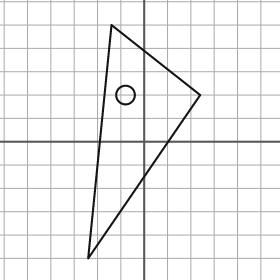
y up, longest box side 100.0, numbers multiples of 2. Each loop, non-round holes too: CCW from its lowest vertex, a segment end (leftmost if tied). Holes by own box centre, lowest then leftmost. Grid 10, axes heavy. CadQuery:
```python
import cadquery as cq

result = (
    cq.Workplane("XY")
    .moveTo(-24.0, -50.0)
    .lineTo(24.0, 20.0)
    .lineTo(-14.0, 50.0)
    .close()
    .moveTo(-8.0, 20.0)
    .circle(4.0)
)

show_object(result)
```